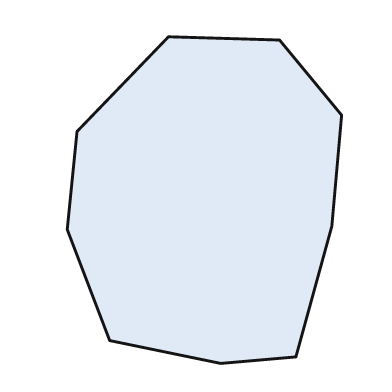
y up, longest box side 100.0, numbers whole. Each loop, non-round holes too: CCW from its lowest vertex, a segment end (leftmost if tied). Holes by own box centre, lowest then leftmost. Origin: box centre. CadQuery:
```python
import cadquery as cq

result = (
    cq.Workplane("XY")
    .moveTo(5.0, -50.0)
    .lineTo(28.0, -48.0)
    .lineTo(39.0, -8.0)
    .lineTo(42.0, 26.0)
    .lineTo(23.0, 49.0)
    .lineTo(-11.0, 50.0)
    .lineTo(-39.0, 21.0)
    .lineTo(-42.0, -9.0)
    .lineTo(-29.0, -43.0)
    .close()
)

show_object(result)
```